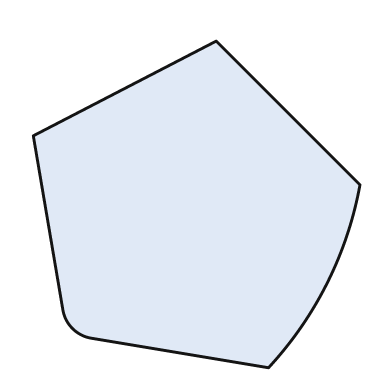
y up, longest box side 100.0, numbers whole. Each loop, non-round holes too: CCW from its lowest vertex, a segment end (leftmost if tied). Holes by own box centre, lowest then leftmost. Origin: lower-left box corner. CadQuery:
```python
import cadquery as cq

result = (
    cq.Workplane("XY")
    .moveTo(72.0, 0.0)
    .threePointArc((90.0, 26.0), (100.0, 56.0))
    .lineTo(56.0, 100.0)
    .lineTo(0.0, 71.0)
    .lineTo(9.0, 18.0)
    .threePointArc((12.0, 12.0), (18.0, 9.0))
    .close()
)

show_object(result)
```